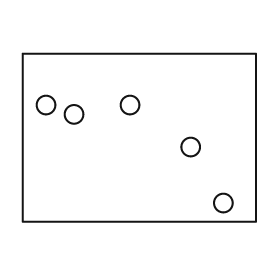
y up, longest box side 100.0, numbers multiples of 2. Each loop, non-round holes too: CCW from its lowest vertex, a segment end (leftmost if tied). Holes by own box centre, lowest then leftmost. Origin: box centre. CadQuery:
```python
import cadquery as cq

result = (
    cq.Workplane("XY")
    .moveTo(-50.0, -36.0)
    .lineTo(50.0, -36.0)
    .lineTo(50.0, 36.0)
    .lineTo(-50.0, 36.0)
    .close()
    .moveTo(36.0, -28.0)
    .circle(4.0)
    .moveTo(22.0, -4.0)
    .circle(4.0)
    .moveTo(-28.0, 10.0)
    .circle(4.0)
    .moveTo(-40.0, 14.0)
    .circle(4.0)
    .moveTo(-4.0, 14.0)
    .circle(4.0)
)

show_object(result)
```